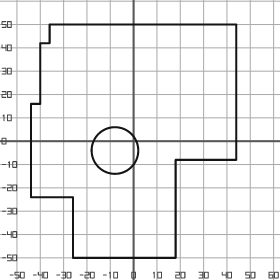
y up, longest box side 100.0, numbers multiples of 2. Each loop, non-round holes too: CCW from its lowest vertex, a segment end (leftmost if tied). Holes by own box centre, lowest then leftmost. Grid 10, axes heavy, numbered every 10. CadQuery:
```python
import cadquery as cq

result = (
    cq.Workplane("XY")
    .moveTo(-26.0, -50.0)
    .lineTo(18.0, -50.0)
    .lineTo(18.0, -8.0)
    .lineTo(44.0, -8.0)
    .lineTo(44.0, 50.0)
    .lineTo(-36.0, 50.0)
    .lineTo(-36.0, 42.0)
    .lineTo(-40.0, 42.0)
    .lineTo(-40.0, 16.0)
    .lineTo(-44.0, 16.0)
    .lineTo(-44.0, -24.0)
    .lineTo(-26.0, -24.0)
    .close()
    .moveTo(-8.0, -4.0)
    .circle(10.0)
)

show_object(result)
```